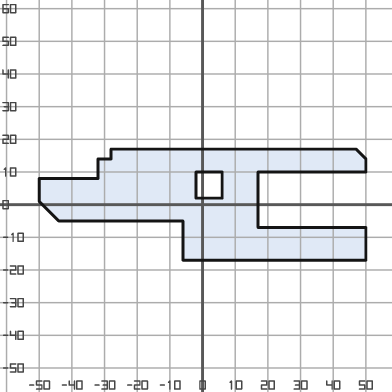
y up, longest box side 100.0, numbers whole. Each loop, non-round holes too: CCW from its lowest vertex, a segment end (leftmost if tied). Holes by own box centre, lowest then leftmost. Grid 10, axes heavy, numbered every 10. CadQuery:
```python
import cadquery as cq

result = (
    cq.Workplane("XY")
    .moveTo(-6.0, -17.0)
    .lineTo(50.0, -17.0)
    .lineTo(50.0, -7.0)
    .lineTo(17.0, -7.0)
    .lineTo(17.0, 10.0)
    .lineTo(50.0, 10.0)
    .lineTo(50.0, 14.0)
    .lineTo(47.0, 17.0)
    .lineTo(-28.0, 17.0)
    .lineTo(-28.0, 14.0)
    .lineTo(-32.0, 14.0)
    .lineTo(-32.0, 8.0)
    .lineTo(-50.0, 8.0)
    .lineTo(-50.0, 1.0)
    .lineTo(-44.0, -5.0)
    .lineTo(-6.0, -5.0)
    .close()
    .moveTo(-2.0, 2.0)
    .lineTo(6.0, 2.0)
    .lineTo(6.0, 10.0)
    .lineTo(-2.0, 10.0)
    .close()
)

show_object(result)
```